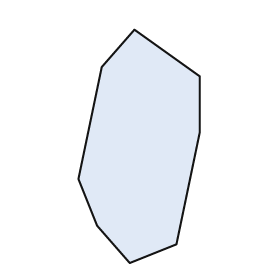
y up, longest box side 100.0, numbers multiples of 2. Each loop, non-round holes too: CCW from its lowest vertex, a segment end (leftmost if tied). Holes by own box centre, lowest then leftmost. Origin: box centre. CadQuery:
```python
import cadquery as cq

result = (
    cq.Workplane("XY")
    .moveTo(-4.0, -50.0)
    .lineTo(16.0, -42.0)
    .lineTo(26.0, 6.0)
    .lineTo(26.0, 30.0)
    .lineTo(-2.0, 50.0)
    .lineTo(-16.0, 34.0)
    .lineTo(-26.0, -14.0)
    .lineTo(-18.0, -34.0)
    .close()
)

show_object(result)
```